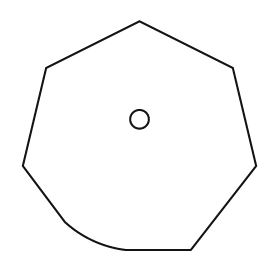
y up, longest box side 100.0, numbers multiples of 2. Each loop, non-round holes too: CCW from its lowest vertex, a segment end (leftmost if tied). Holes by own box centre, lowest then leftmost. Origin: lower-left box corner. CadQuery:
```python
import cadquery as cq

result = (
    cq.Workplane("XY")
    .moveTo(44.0, 0.0)
    .lineTo(72.0, 0.0)
    .lineTo(100.0, 36.0)
    .lineTo(90.0, 78.0)
    .lineTo(50.0, 98.0)
    .lineTo(10.0, 78.0)
    .lineTo(0.0, 36.0)
    .lineTo(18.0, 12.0)
    .threePointArc((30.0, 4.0), (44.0, 0.0))
    .close()
    .moveTo(50.0, 56.0)
    .circle(4.0)
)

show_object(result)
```